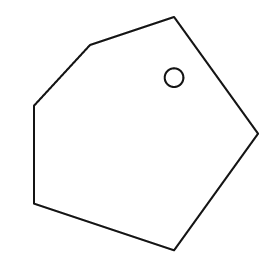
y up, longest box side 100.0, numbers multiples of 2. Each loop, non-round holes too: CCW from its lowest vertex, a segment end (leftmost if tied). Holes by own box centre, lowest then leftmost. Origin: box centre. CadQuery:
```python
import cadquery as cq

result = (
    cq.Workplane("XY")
    .moveTo(12.0, -50.0)
    .lineTo(48.0, 0.0)
    .lineTo(12.0, 50.0)
    .lineTo(-24.0, 38.0)
    .lineTo(-48.0, 12.0)
    .lineTo(-48.0, -30.0)
    .close()
    .moveTo(12.0, 24.0)
    .circle(4.0)
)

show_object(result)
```